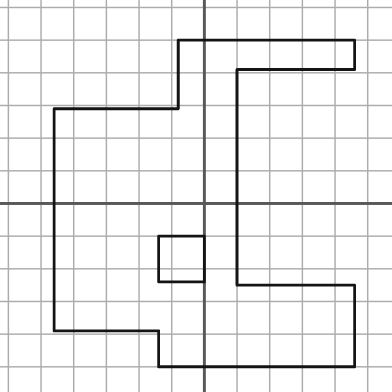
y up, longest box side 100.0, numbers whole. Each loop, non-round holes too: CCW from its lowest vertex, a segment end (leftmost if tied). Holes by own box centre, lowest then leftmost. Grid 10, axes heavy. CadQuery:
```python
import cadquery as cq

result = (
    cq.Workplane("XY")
    .moveTo(-14.0, -50.0)
    .lineTo(46.0, -50.0)
    .lineTo(46.0, -25.0)
    .lineTo(10.0, -25.0)
    .lineTo(10.0, 41.0)
    .lineTo(46.0, 41.0)
    .lineTo(46.0, 50.0)
    .lineTo(-8.0, 50.0)
    .lineTo(-8.0, 29.0)
    .lineTo(-46.0, 29.0)
    .lineTo(-46.0, -39.0)
    .lineTo(-14.0, -39.0)
    .close()
    .moveTo(-14.0, -24.0)
    .lineTo(0.0, -24.0)
    .lineTo(0.0, -10.0)
    .lineTo(-14.0, -10.0)
    .close()
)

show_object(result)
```